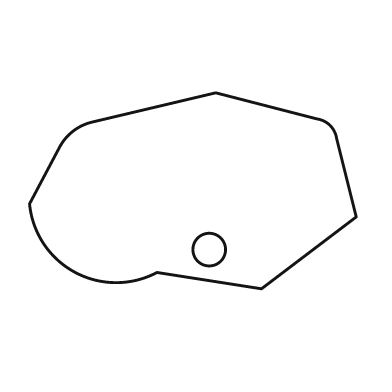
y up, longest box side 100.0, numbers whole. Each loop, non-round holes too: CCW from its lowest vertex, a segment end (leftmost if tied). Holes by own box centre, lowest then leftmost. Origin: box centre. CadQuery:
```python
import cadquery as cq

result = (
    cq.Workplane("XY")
    .moveTo(21.0, -30.0)
    .lineTo(50.0, -8.0)
    .lineTo(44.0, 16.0)
    .threePointArc((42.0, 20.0), (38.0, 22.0))
    .lineTo(7.0, 30.0)
    .lineTo(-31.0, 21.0)
    .threePointArc((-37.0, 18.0), (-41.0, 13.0))
    .lineTo(-50.0, -4.0)
    .threePointArc((-36.0, -25.0), (-11.0, -25.0))
    .close()
    .moveTo(5.0, -18.0)
    .circle(5.0)
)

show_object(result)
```